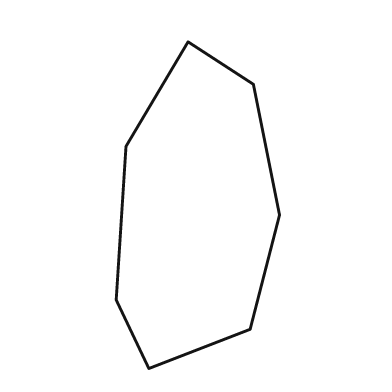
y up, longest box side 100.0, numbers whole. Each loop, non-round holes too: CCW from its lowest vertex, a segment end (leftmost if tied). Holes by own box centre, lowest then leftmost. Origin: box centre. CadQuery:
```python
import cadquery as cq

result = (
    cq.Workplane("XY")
    .moveTo(-15.0, -50.0)
    .lineTo(16.0, -38.0)
    .lineTo(25.0, -3.0)
    .lineTo(17.0, 37.0)
    .lineTo(-3.0, 50.0)
    .lineTo(-22.0, 18.0)
    .lineTo(-25.0, -29.0)
    .close()
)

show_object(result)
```